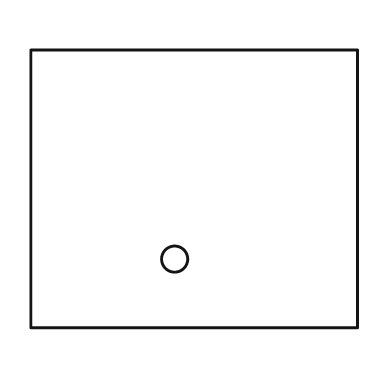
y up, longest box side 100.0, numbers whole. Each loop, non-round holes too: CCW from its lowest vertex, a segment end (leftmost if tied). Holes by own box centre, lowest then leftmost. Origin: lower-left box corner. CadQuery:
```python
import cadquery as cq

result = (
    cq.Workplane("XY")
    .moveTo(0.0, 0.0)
    .lineTo(100.0, 0.0)
    .lineTo(100.0, 85.0)
    .lineTo(0.0, 85.0)
    .close()
    .moveTo(44.0, 21.0)
    .circle(4.0)
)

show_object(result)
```